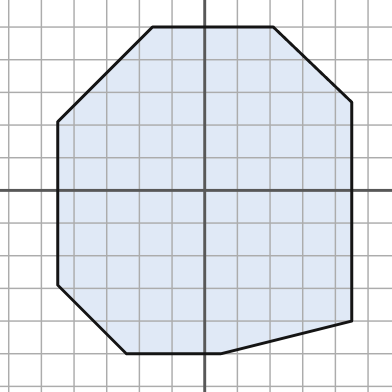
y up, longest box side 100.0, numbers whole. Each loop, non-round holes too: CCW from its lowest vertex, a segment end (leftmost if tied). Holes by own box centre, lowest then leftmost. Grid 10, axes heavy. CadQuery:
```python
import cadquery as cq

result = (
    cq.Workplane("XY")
    .moveTo(-24.0, -50.0)
    .lineTo(5.0, -50.0)
    .lineTo(45.0, -40.0)
    .lineTo(45.0, 27.0)
    .lineTo(21.0, 50.0)
    .lineTo(-16.0, 50.0)
    .lineTo(-45.0, 21.0)
    .lineTo(-45.0, -29.0)
    .close()
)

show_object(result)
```